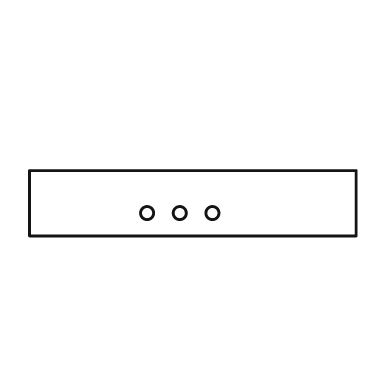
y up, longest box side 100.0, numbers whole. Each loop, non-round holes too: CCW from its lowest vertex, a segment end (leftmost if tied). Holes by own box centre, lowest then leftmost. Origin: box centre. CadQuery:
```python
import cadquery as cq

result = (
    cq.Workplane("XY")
    .moveTo(-50.0, -10.0)
    .lineTo(50.0, -10.0)
    .lineTo(50.0, 10.0)
    .lineTo(-50.0, 10.0)
    .close()
    .moveTo(-14.0, -3.0)
    .circle(2.0)
    .moveTo(-4.0, -3.0)
    .circle(2.0)
    .moveTo(6.0, -3.0)
    .circle(2.0)
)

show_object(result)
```